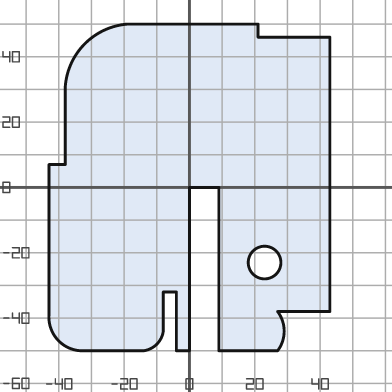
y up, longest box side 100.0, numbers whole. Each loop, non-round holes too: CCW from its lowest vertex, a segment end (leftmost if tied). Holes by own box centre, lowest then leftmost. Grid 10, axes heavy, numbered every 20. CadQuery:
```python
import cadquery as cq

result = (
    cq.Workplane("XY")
    .moveTo(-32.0, -50.0)
    .lineTo(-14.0, -50.0)
    .threePointArc((-10.0, -48.0), (-8.0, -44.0))
    .lineTo(-8.0, -32.0)
    .lineTo(-4.0, -32.0)
    .lineTo(-4.0, -50.0)
    .lineTo(0.0, -50.0)
    .lineTo(0.0, 0.0)
    .lineTo(9.0, 0.0)
    .lineTo(9.0, -50.0)
    .lineTo(27.0, -50.0)
    .threePointArc((29.0, -44.0), (27.0, -38.0))
    .lineTo(43.0, -38.0)
    .lineTo(43.0, 46.0)
    .lineTo(21.0, 46.0)
    .lineTo(21.0, 50.0)
    .lineTo(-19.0, 50.0)
    .threePointArc((-32.0, 44.0), (-38.0, 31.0))
    .lineTo(-38.0, 7.0)
    .lineTo(-43.0, 7.0)
    .lineTo(-43.0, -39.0)
    .threePointArc((-40.0, -47.0), (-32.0, -50.0))
    .close()
    .moveTo(23.0, -23.0)
    .circle(5.0)
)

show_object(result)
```